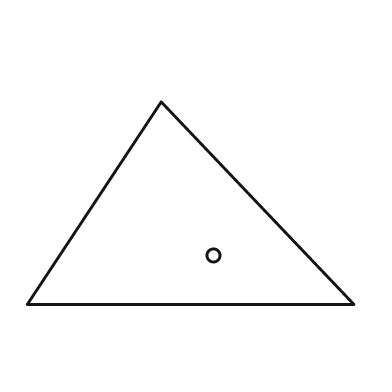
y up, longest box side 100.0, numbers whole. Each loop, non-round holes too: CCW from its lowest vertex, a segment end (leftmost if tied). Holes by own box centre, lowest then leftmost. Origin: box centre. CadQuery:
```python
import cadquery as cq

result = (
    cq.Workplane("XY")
    .moveTo(-50.0, -31.0)
    .lineTo(50.0, -31.0)
    .lineTo(-9.0, 31.0)
    .close()
    .moveTo(7.0, -16.0)
    .circle(2.0)
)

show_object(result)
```